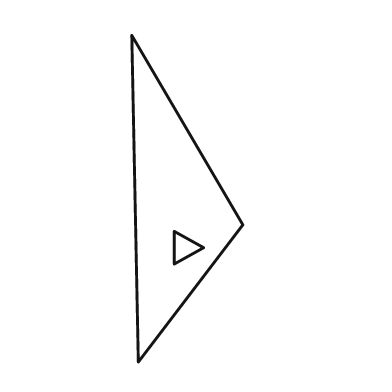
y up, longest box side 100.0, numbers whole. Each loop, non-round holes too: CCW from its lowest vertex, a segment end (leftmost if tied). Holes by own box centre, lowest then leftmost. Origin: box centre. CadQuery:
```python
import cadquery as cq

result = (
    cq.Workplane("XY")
    .moveTo(-15.0, -50.0)
    .lineTo(17.0, -8.0)
    .lineTo(-17.0, 50.0)
    .close()
    .moveTo(-4.0, -20.0)
    .lineTo(5.0, -15.0)
    .lineTo(-4.0, -10.0)
    .close()
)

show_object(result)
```